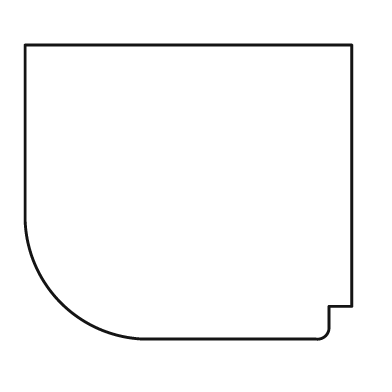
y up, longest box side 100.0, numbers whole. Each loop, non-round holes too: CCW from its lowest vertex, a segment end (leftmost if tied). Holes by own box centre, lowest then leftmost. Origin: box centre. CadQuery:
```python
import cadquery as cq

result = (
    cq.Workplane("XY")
    .moveTo(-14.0, -45.0)
    .lineTo(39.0, -45.0)
    .threePointArc((42.0, -44.0), (43.0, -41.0))
    .lineTo(43.0, -35.0)
    .lineTo(50.0, -35.0)
    .lineTo(50.0, 45.0)
    .lineTo(-50.0, 45.0)
    .lineTo(-50.0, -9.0)
    .threePointArc((-39.0, -34.0), (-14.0, -45.0))
    .close()
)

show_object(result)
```